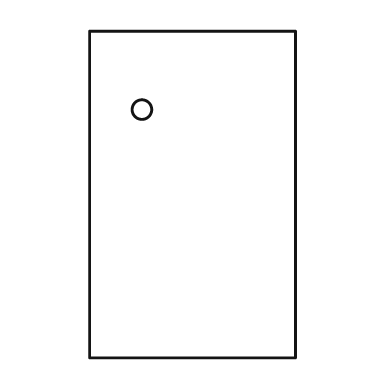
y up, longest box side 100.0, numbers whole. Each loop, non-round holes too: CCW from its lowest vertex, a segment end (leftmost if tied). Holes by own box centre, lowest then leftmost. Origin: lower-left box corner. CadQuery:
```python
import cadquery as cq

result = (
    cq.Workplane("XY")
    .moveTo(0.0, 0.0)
    .lineTo(63.0, 0.0)
    .lineTo(63.0, 100.0)
    .lineTo(0.0, 100.0)
    .close()
    .moveTo(16.0, 76.0)
    .circle(3.0)
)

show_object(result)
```